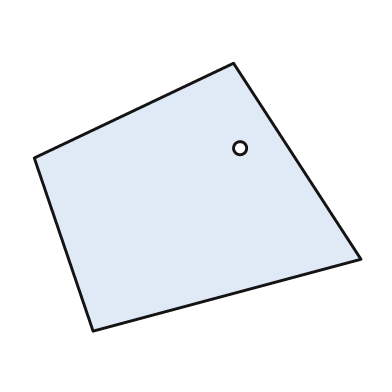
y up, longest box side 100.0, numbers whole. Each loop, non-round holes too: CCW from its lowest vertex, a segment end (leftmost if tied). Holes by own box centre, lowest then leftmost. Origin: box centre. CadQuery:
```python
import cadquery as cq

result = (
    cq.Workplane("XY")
    .moveTo(-32.0, -41.0)
    .lineTo(50.0, -19.0)
    .lineTo(11.0, 41.0)
    .lineTo(-50.0, 12.0)
    .close()
    .moveTo(13.0, 15.0)
    .circle(2.0)
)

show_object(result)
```